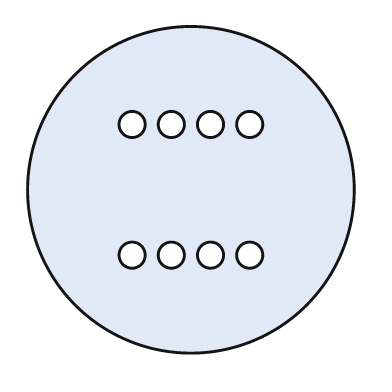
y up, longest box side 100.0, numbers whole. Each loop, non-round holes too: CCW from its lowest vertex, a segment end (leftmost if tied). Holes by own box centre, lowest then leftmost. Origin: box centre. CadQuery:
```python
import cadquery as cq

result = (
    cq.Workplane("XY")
    .moveTo(0.0, 0.0)
    .circle(50.0)
    .moveTo(-18.0, -20.0)
    .circle(4.0)
    .moveTo(-6.0, -20.0)
    .circle(4.0)
    .moveTo(6.0, -20.0)
    .circle(4.0)
    .moveTo(18.0, -20.0)
    .circle(4.0)
    .moveTo(-18.0, 20.0)
    .circle(4.0)
    .moveTo(-6.0, 20.0)
    .circle(4.0)
    .moveTo(6.0, 20.0)
    .circle(4.0)
    .moveTo(18.0, 20.0)
    .circle(4.0)
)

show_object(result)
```